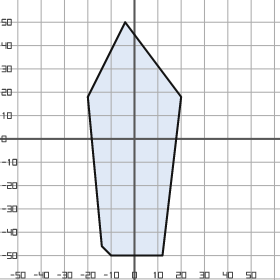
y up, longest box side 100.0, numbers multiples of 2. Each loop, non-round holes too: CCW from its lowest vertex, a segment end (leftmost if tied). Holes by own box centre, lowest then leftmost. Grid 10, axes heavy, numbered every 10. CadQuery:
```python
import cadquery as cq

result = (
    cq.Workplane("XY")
    .moveTo(-10.0, -50.0)
    .lineTo(12.0, -50.0)
    .lineTo(20.0, 18.0)
    .lineTo(-4.0, 50.0)
    .lineTo(-20.0, 18.0)
    .lineTo(-14.0, -46.0)
    .close()
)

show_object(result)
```